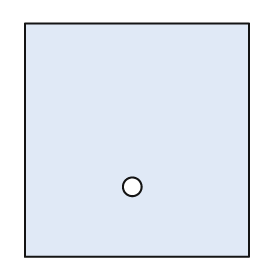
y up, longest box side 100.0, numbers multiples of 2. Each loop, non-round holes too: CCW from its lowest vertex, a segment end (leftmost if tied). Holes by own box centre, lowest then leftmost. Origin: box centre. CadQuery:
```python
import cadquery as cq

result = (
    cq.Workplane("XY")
    .moveTo(-48.0, -50.0)
    .lineTo(48.0, -50.0)
    .lineTo(48.0, 50.0)
    .lineTo(-48.0, 50.0)
    .close()
    .moveTo(-2.0, -20.0)
    .circle(4.0)
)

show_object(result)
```